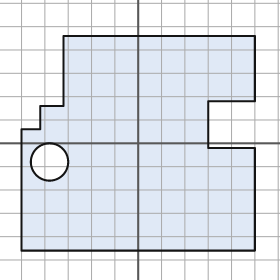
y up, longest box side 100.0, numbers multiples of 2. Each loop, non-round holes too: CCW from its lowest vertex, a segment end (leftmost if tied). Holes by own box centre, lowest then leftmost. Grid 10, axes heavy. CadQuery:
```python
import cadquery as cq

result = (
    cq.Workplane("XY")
    .moveTo(-50.0, -46.0)
    .lineTo(50.0, -46.0)
    .lineTo(50.0, -2.0)
    .lineTo(30.0, -2.0)
    .lineTo(30.0, 18.0)
    .lineTo(50.0, 18.0)
    .lineTo(50.0, 46.0)
    .lineTo(-32.0, 46.0)
    .lineTo(-32.0, 16.0)
    .lineTo(-42.0, 16.0)
    .lineTo(-42.0, 6.0)
    .lineTo(-50.0, 6.0)
    .close()
    .moveTo(-38.0, -8.0)
    .circle(8.0)
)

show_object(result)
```